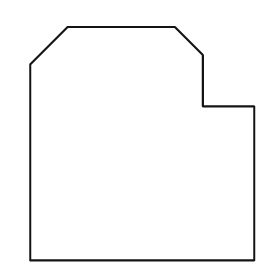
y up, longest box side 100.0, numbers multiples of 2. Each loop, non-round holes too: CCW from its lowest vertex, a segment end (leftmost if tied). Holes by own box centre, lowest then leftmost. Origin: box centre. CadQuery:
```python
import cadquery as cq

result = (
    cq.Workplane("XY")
    .moveTo(-48.0, -50.0)
    .lineTo(48.0, -50.0)
    .lineTo(48.0, 16.0)
    .lineTo(26.0, 16.0)
    .lineTo(26.0, 38.0)
    .lineTo(14.0, 50.0)
    .lineTo(-32.0, 50.0)
    .lineTo(-48.0, 34.0)
    .close()
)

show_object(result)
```